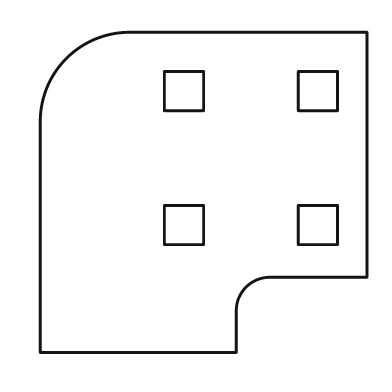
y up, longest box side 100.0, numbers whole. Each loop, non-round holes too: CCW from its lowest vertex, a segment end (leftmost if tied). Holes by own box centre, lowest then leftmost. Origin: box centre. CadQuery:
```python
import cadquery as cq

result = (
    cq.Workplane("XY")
    .moveTo(-50.0, -49.0)
    .lineTo(10.0, -49.0)
    .lineTo(10.0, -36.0)
    .threePointArc((13.0, -29.0), (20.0, -26.0))
    .lineTo(50.0, -26.0)
    .lineTo(50.0, 49.0)
    .lineTo(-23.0, 49.0)
    .threePointArc((-42.0, 41.0), (-50.0, 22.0))
    .close()
    .moveTo(-12.0, -16.0)
    .lineTo(0.0, -16.0)
    .lineTo(0.0, -4.0)
    .lineTo(-12.0, -4.0)
    .close()
    .moveTo(29.0, -16.0)
    .lineTo(41.0, -16.0)
    .lineTo(41.0, -4.0)
    .lineTo(29.0, -4.0)
    .close()
    .moveTo(-12.0, 25.0)
    .lineTo(0.0, 25.0)
    .lineTo(0.0, 37.0)
    .lineTo(-12.0, 37.0)
    .close()
    .moveTo(29.0, 25.0)
    .lineTo(41.0, 25.0)
    .lineTo(41.0, 37.0)
    .lineTo(29.0, 37.0)
    .close()
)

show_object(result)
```